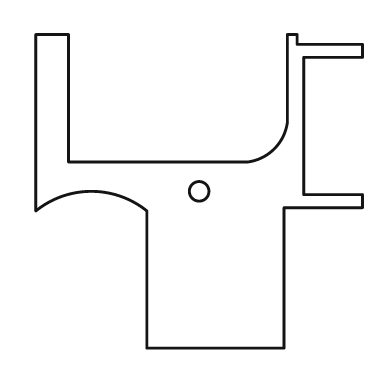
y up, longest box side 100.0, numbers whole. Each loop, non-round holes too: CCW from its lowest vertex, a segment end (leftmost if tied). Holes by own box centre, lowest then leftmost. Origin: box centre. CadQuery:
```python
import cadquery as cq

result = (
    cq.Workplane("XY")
    .moveTo(-16.0, -48.0)
    .lineTo(26.0, -48.0)
    .lineTo(26.0, -5.0)
    .lineTo(50.0, -5.0)
    .lineTo(50.0, -1.0)
    .lineTo(32.0, -1.0)
    .lineTo(32.0, 41.0)
    .lineTo(50.0, 41.0)
    .lineTo(50.0, 45.0)
    .lineTo(30.0, 45.0)
    .lineTo(30.0, 48.0)
    .lineTo(27.0, 48.0)
    .lineTo(27.0, 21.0)
    .threePointArc((23.0, 13.0), (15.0, 9.0))
    .lineTo(-40.0, 9.0)
    .lineTo(-40.0, 48.0)
    .lineTo(-50.0, 48.0)
    .lineTo(-50.0, -6.0)
    .threePointArc((-33.0, 0.0), (-16.0, -6.0))
    .close()
    .moveTo(0.0, 0.0)
    .circle(3.0)
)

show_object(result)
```